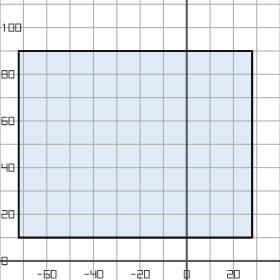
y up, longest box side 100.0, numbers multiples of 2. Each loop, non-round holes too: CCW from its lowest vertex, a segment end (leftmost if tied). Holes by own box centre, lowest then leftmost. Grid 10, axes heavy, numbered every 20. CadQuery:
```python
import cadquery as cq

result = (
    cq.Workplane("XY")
    .moveTo(-72.0, 10.0)
    .lineTo(28.0, 10.0)
    .lineTo(28.0, 90.0)
    .lineTo(-72.0, 90.0)
    .close()
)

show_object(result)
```